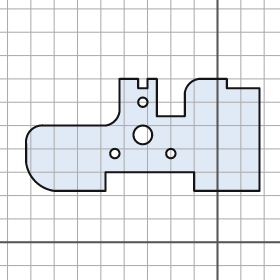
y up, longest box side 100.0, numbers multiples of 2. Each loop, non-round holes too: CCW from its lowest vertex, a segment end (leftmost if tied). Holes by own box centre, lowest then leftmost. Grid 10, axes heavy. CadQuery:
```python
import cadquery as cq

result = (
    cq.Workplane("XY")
    .moveTo(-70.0, 22.0)
    .lineTo(-48.0, 22.0)
    .lineTo(-48.0, 30.0)
    .lineTo(-10.0, 30.0)
    .lineTo(-10.0, 22.0)
    .lineTo(18.0, 22.0)
    .lineTo(18.0, 66.0)
    .lineTo(4.0, 66.0)
    .lineTo(4.0, 70.0)
    .lineTo(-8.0, 70.0)
    .threePointArc((-12.0, 68.0), (-14.0, 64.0))
    .lineTo(-14.0, 54.0)
    .lineTo(-26.0, 54.0)
    .lineTo(-26.0, 70.0)
    .lineTo(-30.0, 70.0)
    .lineTo(-30.0, 66.0)
    .lineTo(-34.0, 66.0)
    .lineTo(-34.0, 70.0)
    .lineTo(-42.0, 70.0)
    .lineTo(-42.0, 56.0)
    .threePointArc((-44.0, 52.0), (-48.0, 50.0))
    .lineTo(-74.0, 50.0)
    .threePointArc((-80.0, 48.0), (-82.0, 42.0))
    .lineTo(-82.0, 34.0)
    .threePointArc((-78.0, 26.0), (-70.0, 22.0))
    .close()
    .moveTo(-44.0, 38.0)
    .circle(2.0)
    .moveTo(-20.0, 38.0)
    .circle(2.0)
    .moveTo(-32.0, 46.0)
    .circle(4.0)
    .moveTo(-32.0, 60.0)
    .circle(2.0)
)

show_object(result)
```